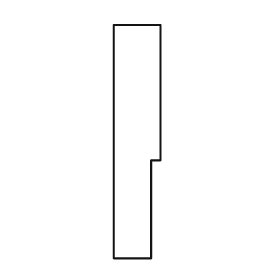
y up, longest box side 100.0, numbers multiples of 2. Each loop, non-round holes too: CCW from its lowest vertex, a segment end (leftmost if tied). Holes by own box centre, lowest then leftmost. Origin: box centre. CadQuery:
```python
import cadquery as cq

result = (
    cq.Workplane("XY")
    .moveTo(-10.0, -50.0)
    .lineTo(6.0, -50.0)
    .lineTo(6.0, -8.0)
    .lineTo(10.0, -8.0)
    .lineTo(10.0, 50.0)
    .lineTo(-10.0, 50.0)
    .close()
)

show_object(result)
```